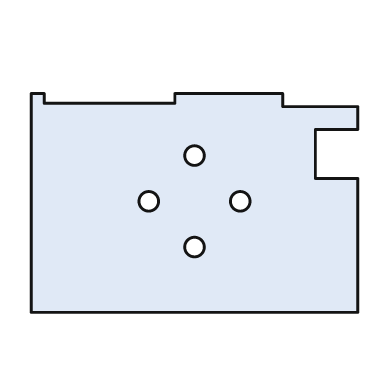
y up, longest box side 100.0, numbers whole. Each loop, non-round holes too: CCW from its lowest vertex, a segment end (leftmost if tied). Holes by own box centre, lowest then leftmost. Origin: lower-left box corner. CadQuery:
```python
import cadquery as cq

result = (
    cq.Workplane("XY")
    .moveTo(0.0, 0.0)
    .lineTo(100.0, 0.0)
    .lineTo(100.0, 41.0)
    .lineTo(87.0, 41.0)
    .lineTo(87.0, 56.0)
    .lineTo(100.0, 56.0)
    .lineTo(100.0, 63.0)
    .lineTo(77.0, 63.0)
    .lineTo(77.0, 67.0)
    .lineTo(44.0, 67.0)
    .lineTo(44.0, 64.0)
    .lineTo(4.0, 64.0)
    .lineTo(4.0, 67.0)
    .lineTo(0.0, 67.0)
    .close()
    .moveTo(50.0, 20.0)
    .circle(3.0)
    .moveTo(36.0, 34.0)
    .circle(3.0)
    .moveTo(64.0, 34.0)
    .circle(3.0)
    .moveTo(50.0, 48.0)
    .circle(3.0)
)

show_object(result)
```